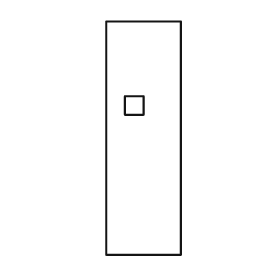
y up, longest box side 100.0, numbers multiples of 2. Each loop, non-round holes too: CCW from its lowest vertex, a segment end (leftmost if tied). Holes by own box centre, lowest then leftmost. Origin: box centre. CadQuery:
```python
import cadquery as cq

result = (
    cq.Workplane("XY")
    .moveTo(-16.0, -50.0)
    .lineTo(16.0, -50.0)
    .lineTo(16.0, 50.0)
    .lineTo(-16.0, 50.0)
    .close()
    .moveTo(-8.0, 10.0)
    .lineTo(0.0, 10.0)
    .lineTo(0.0, 18.0)
    .lineTo(-8.0, 18.0)
    .close()
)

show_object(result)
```